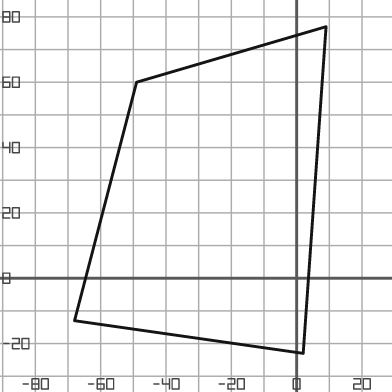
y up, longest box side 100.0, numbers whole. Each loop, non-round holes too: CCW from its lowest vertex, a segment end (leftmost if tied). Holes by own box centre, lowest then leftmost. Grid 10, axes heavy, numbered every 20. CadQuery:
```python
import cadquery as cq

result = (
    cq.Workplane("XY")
    .moveTo(2.0, -23.0)
    .lineTo(9.0, 77.0)
    .lineTo(-49.0, 60.0)
    .lineTo(-68.0, -13.0)
    .close()
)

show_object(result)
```